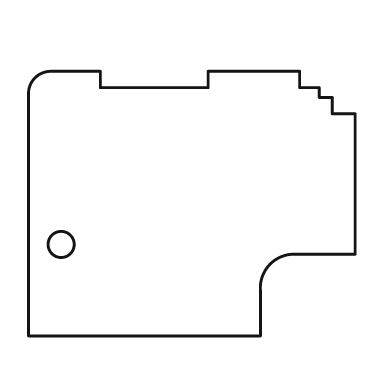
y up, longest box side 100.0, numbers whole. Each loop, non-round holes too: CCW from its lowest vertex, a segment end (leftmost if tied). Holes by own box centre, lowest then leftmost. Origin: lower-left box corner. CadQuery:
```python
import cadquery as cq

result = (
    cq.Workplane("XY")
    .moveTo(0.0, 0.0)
    .lineTo(71.0, 0.0)
    .lineTo(71.0, 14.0)
    .threePointArc((74.0, 22.0), (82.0, 25.0))
    .lineTo(100.0, 25.0)
    .lineTo(100.0, 68.0)
    .lineTo(93.0, 68.0)
    .lineTo(93.0, 73.0)
    .lineTo(89.0, 73.0)
    .lineTo(89.0, 76.0)
    .lineTo(83.0, 76.0)
    .lineTo(83.0, 81.0)
    .lineTo(55.0, 81.0)
    .lineTo(55.0, 76.0)
    .lineTo(22.0, 76.0)
    .lineTo(22.0, 81.0)
    .lineTo(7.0, 81.0)
    .threePointArc((2.0, 79.0), (0.0, 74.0))
    .close()
    .moveTo(10.0, 28.0)
    .circle(4.0)
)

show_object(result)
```